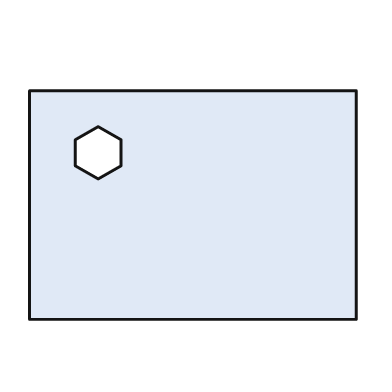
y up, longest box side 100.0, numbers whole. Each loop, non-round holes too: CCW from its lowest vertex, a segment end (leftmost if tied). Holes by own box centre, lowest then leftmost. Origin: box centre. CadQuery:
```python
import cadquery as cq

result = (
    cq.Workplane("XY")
    .moveTo(-50.0, -35.0)
    .lineTo(50.0, -35.0)
    .lineTo(50.0, 35.0)
    .lineTo(-50.0, 35.0)
    .close()
    .moveTo(-29.0, 8.0)
    .lineTo(-22.0, 12.0)
    .lineTo(-22.0, 20.0)
    .lineTo(-29.0, 24.0)
    .lineTo(-36.0, 20.0)
    .lineTo(-36.0, 12.0)
    .close()
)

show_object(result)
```